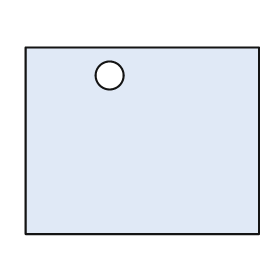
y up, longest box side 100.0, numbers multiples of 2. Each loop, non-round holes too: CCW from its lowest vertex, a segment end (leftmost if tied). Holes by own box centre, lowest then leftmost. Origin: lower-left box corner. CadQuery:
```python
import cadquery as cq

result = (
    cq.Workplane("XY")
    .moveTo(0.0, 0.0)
    .lineTo(100.0, 0.0)
    .lineTo(100.0, 80.0)
    .lineTo(0.0, 80.0)
    .close()
    .moveTo(36.0, 68.0)
    .circle(6.0)
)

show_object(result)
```